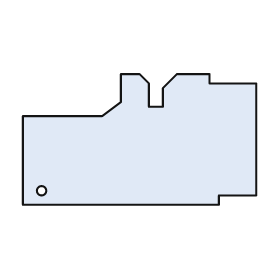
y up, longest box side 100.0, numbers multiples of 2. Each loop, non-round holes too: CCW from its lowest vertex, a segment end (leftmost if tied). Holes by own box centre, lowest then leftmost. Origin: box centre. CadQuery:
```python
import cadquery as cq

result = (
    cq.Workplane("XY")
    .moveTo(-50.0, -28.0)
    .lineTo(34.0, -28.0)
    .lineTo(34.0, -24.0)
    .lineTo(50.0, -24.0)
    .lineTo(50.0, 24.0)
    .lineTo(30.0, 24.0)
    .lineTo(30.0, 28.0)
    .lineTo(16.0, 28.0)
    .lineTo(10.0, 22.0)
    .lineTo(10.0, 14.0)
    .lineTo(4.0, 14.0)
    .lineTo(4.0, 24.0)
    .lineTo(0.0, 28.0)
    .lineTo(-8.0, 28.0)
    .lineTo(-8.0, 16.0)
    .lineTo(-16.0, 10.0)
    .lineTo(-50.0, 10.0)
    .close()
    .moveTo(-42.0, -22.0)
    .circle(2.0)
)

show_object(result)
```